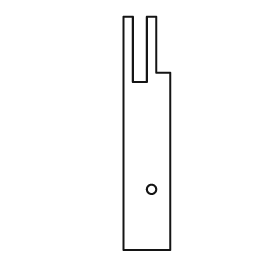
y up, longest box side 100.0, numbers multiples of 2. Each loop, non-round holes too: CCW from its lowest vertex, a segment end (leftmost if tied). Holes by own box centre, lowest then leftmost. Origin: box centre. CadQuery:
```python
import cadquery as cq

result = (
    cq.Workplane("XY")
    .moveTo(-10.0, -50.0)
    .lineTo(10.0, -50.0)
    .lineTo(10.0, 26.0)
    .lineTo(4.0, 26.0)
    .lineTo(4.0, 50.0)
    .lineTo(0.0, 50.0)
    .lineTo(0.0, 22.0)
    .lineTo(-6.0, 22.0)
    .lineTo(-6.0, 50.0)
    .lineTo(-10.0, 50.0)
    .close()
    .moveTo(2.0, -24.0)
    .circle(2.0)
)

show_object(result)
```